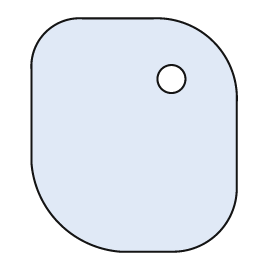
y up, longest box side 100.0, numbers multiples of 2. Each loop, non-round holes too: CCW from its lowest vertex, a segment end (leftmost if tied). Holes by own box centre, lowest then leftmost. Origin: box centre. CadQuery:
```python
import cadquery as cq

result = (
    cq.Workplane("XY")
    .moveTo(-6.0, -50.0)
    .lineTo(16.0, -50.0)
    .threePointArc((36.0, -42.0), (44.0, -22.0))
    .lineTo(44.0, 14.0)
    .threePointArc((34.0, 40.0), (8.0, 50.0))
    .lineTo(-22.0, 50.0)
    .threePointArc((-38.0, 44.0), (-44.0, 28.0))
    .lineTo(-44.0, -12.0)
    .threePointArc((-32.0, -38.0), (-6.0, -50.0))
    .close()
    .moveTo(16.0, 24.0)
    .circle(6.0)
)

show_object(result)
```